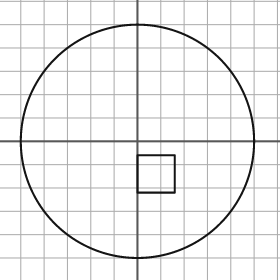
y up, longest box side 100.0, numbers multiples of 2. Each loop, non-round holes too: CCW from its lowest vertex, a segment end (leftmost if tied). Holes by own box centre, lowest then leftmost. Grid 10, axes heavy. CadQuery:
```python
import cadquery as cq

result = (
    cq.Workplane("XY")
    .moveTo(0.0, 0.0)
    .circle(50.0)
    .moveTo(0.0, -22.0)
    .lineTo(16.0, -22.0)
    .lineTo(16.0, -6.0)
    .lineTo(0.0, -6.0)
    .close()
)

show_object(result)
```